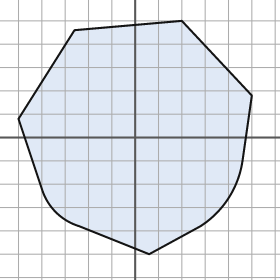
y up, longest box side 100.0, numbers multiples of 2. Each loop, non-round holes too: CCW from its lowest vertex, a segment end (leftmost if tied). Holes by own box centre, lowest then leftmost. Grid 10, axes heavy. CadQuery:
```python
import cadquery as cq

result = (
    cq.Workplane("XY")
    .moveTo(6.0, -50.0)
    .lineTo(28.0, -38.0)
    .threePointArc((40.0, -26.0), (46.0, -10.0))
    .lineTo(50.0, 18.0)
    .lineTo(20.0, 50.0)
    .lineTo(-26.0, 46.0)
    .lineTo(-50.0, 8.0)
    .lineTo(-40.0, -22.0)
    .threePointArc((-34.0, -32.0), (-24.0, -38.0))
    .close()
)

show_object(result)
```